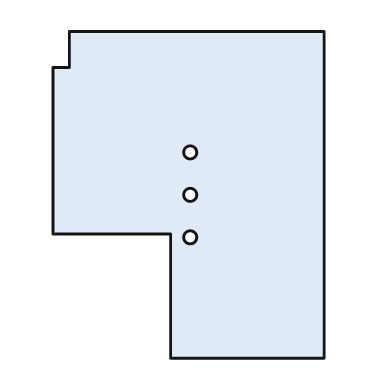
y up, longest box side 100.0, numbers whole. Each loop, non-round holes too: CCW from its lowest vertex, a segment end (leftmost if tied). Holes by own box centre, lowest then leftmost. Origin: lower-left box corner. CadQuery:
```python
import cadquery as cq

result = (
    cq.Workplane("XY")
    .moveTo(36.0, 0.0)
    .lineTo(83.0, 0.0)
    .lineTo(83.0, 100.0)
    .lineTo(5.0, 100.0)
    .lineTo(5.0, 89.0)
    .lineTo(0.0, 89.0)
    .lineTo(0.0, 38.0)
    .lineTo(36.0, 38.0)
    .close()
    .moveTo(42.0, 37.0)
    .circle(2.0)
    .moveTo(42.0, 50.0)
    .circle(2.0)
    .moveTo(42.0, 63.0)
    .circle(2.0)
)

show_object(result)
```